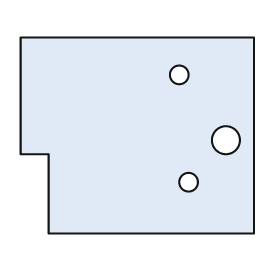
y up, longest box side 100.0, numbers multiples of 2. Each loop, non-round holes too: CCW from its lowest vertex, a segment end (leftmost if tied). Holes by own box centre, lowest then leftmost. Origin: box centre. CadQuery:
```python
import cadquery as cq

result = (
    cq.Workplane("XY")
    .moveTo(-38.0, -42.0)
    .lineTo(50.0, -42.0)
    .lineTo(50.0, 42.0)
    .lineTo(-50.0, 42.0)
    .lineTo(-50.0, -8.0)
    .lineTo(-38.0, -8.0)
    .close()
    .moveTo(22.0, -20.0)
    .circle(4.0)
    .moveTo(38.0, -2.0)
    .circle(6.0)
    .moveTo(18.0, 26.0)
    .circle(4.0)
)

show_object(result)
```